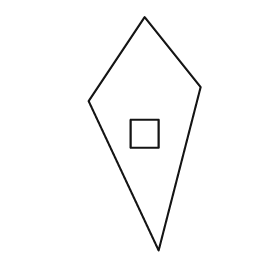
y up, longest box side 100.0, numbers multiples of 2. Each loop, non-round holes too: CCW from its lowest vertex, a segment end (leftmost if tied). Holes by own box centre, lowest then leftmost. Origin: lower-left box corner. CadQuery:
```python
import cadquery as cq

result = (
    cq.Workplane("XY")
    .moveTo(30.0, 0.0)
    .lineTo(48.0, 70.0)
    .lineTo(24.0, 100.0)
    .lineTo(0.0, 64.0)
    .close()
    .moveTo(18.0, 44.0)
    .lineTo(30.0, 44.0)
    .lineTo(30.0, 56.0)
    .lineTo(18.0, 56.0)
    .close()
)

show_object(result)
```